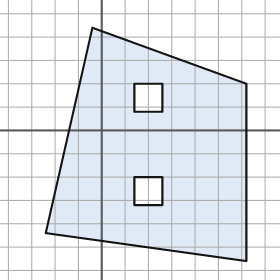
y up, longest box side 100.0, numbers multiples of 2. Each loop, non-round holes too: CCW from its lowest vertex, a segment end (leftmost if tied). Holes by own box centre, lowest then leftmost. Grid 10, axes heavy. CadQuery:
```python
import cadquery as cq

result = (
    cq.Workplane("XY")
    .moveTo(62.0, -56.0)
    .lineTo(62.0, 20.0)
    .lineTo(-4.0, 44.0)
    .lineTo(-24.0, -44.0)
    .close()
    .moveTo(14.0, -32.0)
    .lineTo(26.0, -32.0)
    .lineTo(26.0, -20.0)
    .lineTo(14.0, -20.0)
    .close()
    .moveTo(14.0, 8.0)
    .lineTo(26.0, 8.0)
    .lineTo(26.0, 20.0)
    .lineTo(14.0, 20.0)
    .close()
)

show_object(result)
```